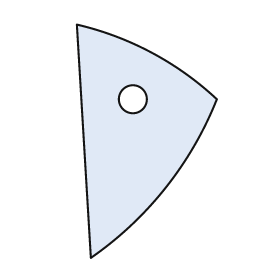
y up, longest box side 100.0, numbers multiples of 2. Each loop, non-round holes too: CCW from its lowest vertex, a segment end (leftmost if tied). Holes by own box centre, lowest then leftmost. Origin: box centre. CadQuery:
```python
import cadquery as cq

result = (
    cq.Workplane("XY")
    .moveTo(-24.0, -50.0)
    .threePointArc((8.0, -20.0), (30.0, 18.0))
    .threePointArc((2.0, 38.0), (-30.0, 50.0))
    .close()
    .moveTo(-6.0, 18.0)
    .circle(6.0)
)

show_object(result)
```